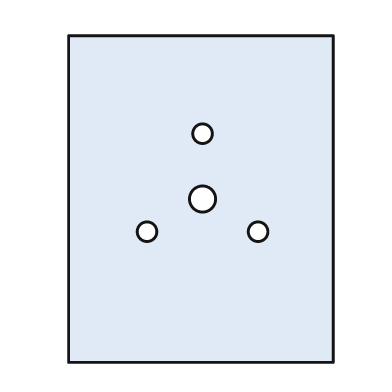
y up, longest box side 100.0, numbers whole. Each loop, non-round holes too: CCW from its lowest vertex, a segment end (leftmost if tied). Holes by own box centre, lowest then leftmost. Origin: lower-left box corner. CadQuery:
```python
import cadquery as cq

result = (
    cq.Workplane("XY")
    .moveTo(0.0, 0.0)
    .lineTo(81.0, 0.0)
    .lineTo(81.0, 100.0)
    .lineTo(0.0, 100.0)
    .close()
    .moveTo(24.0, 40.0)
    .circle(3.0)
    .moveTo(58.0, 40.0)
    .circle(3.0)
    .moveTo(41.0, 50.0)
    .circle(4.0)
    .moveTo(41.0, 70.0)
    .circle(3.0)
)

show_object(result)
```